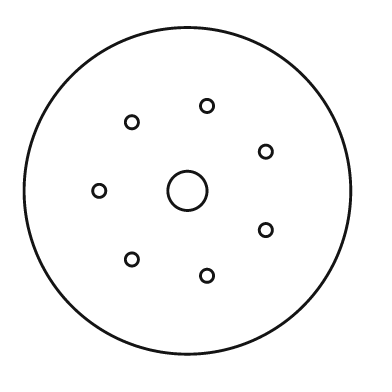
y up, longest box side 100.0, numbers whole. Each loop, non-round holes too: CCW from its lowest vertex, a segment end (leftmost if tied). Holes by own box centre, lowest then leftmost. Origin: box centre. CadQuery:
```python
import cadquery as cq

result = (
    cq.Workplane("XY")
    .moveTo(0.0, 0.0)
    .circle(50.0)
    .moveTo(6.0, -26.0)
    .circle(2.0)
    .moveTo(-17.0, -21.0)
    .circle(2.0)
    .moveTo(24.0, -12.0)
    .circle(2.0)
    .moveTo(-27.0, 0.0)
    .circle(2.0)
    .moveTo(0.0, 0.0)
    .circle(6.0)
    .moveTo(24.0, 12.0)
    .circle(2.0)
    .moveTo(-17.0, 21.0)
    .circle(2.0)
    .moveTo(6.0, 26.0)
    .circle(2.0)
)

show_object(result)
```